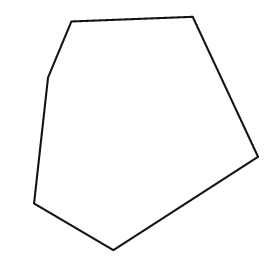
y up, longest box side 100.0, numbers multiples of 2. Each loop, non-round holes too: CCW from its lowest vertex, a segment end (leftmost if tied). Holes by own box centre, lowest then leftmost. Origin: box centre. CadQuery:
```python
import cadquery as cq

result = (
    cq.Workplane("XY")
    .moveTo(-14.0, -50.0)
    .lineTo(48.0, -10.0)
    .lineTo(20.0, 50.0)
    .lineTo(-32.0, 48.0)
    .lineTo(-42.0, 24.0)
    .lineTo(-48.0, -30.0)
    .close()
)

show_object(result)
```